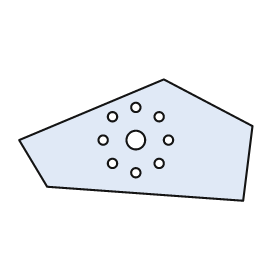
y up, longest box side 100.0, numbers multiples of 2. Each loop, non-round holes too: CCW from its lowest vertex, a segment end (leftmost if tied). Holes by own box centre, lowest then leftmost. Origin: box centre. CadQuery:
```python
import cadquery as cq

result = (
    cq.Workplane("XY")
    .moveTo(46.0, -26.0)
    .lineTo(50.0, 6.0)
    .lineTo(12.0, 26.0)
    .lineTo(-50.0, 0.0)
    .lineTo(-38.0, -20.0)
    .close()
    .moveTo(0.0, -14.0)
    .circle(2.0)
    .moveTo(-10.0, -10.0)
    .circle(2.0)
    .moveTo(10.0, -10.0)
    .circle(2.0)
    .moveTo(-14.0, 0.0)
    .circle(2.0)
    .moveTo(0.0, 0.0)
    .circle(4.0)
    .moveTo(14.0, 0.0)
    .circle(2.0)
    .moveTo(-10.0, 10.0)
    .circle(2.0)
    .moveTo(10.0, 10.0)
    .circle(2.0)
    .moveTo(0.0, 14.0)
    .circle(2.0)
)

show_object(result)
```